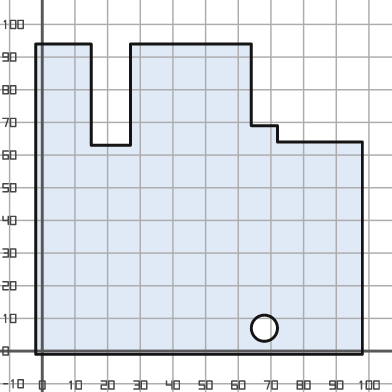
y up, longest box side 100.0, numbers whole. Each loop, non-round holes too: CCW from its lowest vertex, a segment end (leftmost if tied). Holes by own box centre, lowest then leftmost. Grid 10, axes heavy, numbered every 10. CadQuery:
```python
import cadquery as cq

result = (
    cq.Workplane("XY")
    .moveTo(-2.0, -1.0)
    .lineTo(98.0, -1.0)
    .lineTo(98.0, 64.0)
    .lineTo(72.0, 64.0)
    .lineTo(72.0, 69.0)
    .lineTo(64.0, 69.0)
    .lineTo(64.0, 94.0)
    .lineTo(27.0, 94.0)
    .lineTo(27.0, 63.0)
    .lineTo(15.0, 63.0)
    .lineTo(15.0, 94.0)
    .lineTo(-2.0, 94.0)
    .close()
    .moveTo(68.0, 7.0)
    .circle(4.0)
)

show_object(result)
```